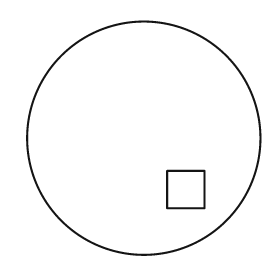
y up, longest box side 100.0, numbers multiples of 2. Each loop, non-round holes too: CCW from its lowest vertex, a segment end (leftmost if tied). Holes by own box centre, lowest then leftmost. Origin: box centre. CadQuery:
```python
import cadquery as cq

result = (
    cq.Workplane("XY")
    .moveTo(0.0, 0.0)
    .circle(50.0)
    .moveTo(10.0, -30.0)
    .lineTo(26.0, -30.0)
    .lineTo(26.0, -14.0)
    .lineTo(10.0, -14.0)
    .close()
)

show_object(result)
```